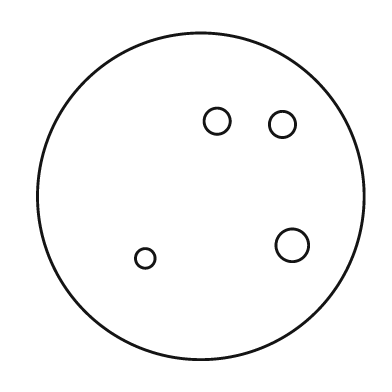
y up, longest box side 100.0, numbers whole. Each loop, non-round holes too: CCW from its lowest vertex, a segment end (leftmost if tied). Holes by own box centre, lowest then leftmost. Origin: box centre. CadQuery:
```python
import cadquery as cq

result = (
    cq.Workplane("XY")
    .moveTo(0.0, 0.0)
    .circle(50.0)
    .moveTo(-17.0, -19.0)
    .circle(3.0)
    .moveTo(28.0, -15.0)
    .circle(5.0)
    .moveTo(25.0, 22.0)
    .circle(4.0)
    .moveTo(5.0, 23.0)
    .circle(4.0)
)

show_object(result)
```